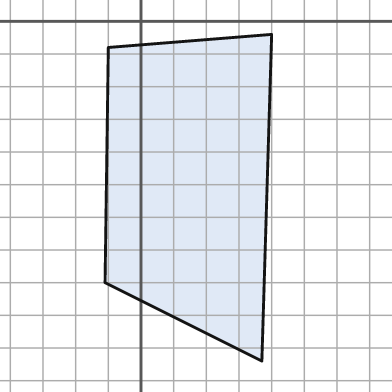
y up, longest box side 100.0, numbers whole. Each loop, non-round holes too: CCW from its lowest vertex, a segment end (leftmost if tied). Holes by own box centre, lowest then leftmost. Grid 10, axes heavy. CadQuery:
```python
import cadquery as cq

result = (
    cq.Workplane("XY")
    .moveTo(37.0, -104.0)
    .lineTo(40.0, -4.0)
    .lineTo(-10.0, -8.0)
    .lineTo(-11.0, -80.0)
    .close()
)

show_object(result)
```